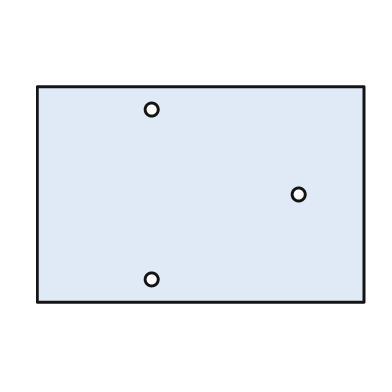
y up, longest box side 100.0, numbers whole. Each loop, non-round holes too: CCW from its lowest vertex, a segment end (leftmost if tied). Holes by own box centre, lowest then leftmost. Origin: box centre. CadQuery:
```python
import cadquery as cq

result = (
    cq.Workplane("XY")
    .moveTo(-50.0, -33.0)
    .lineTo(50.0, -33.0)
    .lineTo(50.0, 33.0)
    .lineTo(-50.0, 33.0)
    .close()
    .moveTo(-15.0, -26.0)
    .circle(2.0)
    .moveTo(30.0, 0.0)
    .circle(2.0)
    .moveTo(-15.0, 26.0)
    .circle(2.0)
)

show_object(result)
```